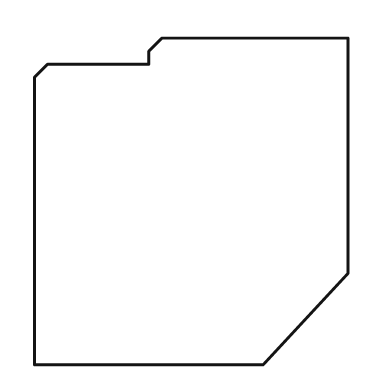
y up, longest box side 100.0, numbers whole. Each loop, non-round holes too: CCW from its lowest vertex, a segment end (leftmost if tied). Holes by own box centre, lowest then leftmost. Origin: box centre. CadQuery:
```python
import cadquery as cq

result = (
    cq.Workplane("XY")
    .moveTo(-48.0, -50.0)
    .lineTo(22.0, -50.0)
    .lineTo(48.0, -22.0)
    .lineTo(48.0, 50.0)
    .lineTo(-9.0, 50.0)
    .lineTo(-13.0, 46.0)
    .lineTo(-13.0, 42.0)
    .lineTo(-44.0, 42.0)
    .lineTo(-48.0, 38.0)
    .close()
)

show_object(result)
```